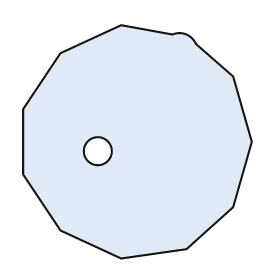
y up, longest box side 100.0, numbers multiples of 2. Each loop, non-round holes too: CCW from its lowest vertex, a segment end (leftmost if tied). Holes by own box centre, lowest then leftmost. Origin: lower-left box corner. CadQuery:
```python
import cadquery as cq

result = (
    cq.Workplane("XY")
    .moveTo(42.0, 0.0)
    .lineTo(70.0, 4.0)
    .lineTo(90.0, 22.0)
    .lineTo(98.0, 50.0)
    .lineTo(90.0, 78.0)
    .lineTo(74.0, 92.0)
    .threePointArc((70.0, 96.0), (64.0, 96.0))
    .lineTo(42.0, 100.0)
    .lineTo(16.0, 88.0)
    .lineTo(0.0, 64.0)
    .lineTo(0.0, 36.0)
    .lineTo(16.0, 12.0)
    .close()
    .moveTo(32.0, 46.0)
    .circle(6.0)
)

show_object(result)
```